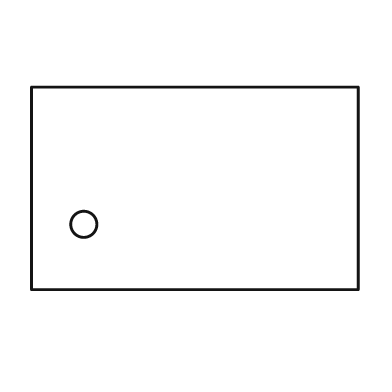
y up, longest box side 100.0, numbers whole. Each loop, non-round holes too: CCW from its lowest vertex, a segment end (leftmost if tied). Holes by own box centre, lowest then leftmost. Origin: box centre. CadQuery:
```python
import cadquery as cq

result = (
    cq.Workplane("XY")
    .moveTo(-50.0, -31.0)
    .lineTo(50.0, -31.0)
    .lineTo(50.0, 31.0)
    .lineTo(-50.0, 31.0)
    .close()
    .moveTo(-34.0, -11.0)
    .circle(4.0)
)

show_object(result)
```